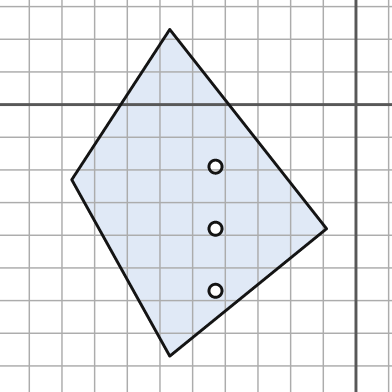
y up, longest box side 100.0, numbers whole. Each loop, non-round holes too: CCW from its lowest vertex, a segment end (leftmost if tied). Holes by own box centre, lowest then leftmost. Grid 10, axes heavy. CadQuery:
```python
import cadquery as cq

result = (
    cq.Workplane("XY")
    .moveTo(-57.0, -77.0)
    .lineTo(-9.0, -38.0)
    .lineTo(-57.0, 23.0)
    .lineTo(-87.0, -23.0)
    .close()
    .moveTo(-43.0, -57.0)
    .circle(2.0)
    .moveTo(-43.0, -38.0)
    .circle(2.0)
    .moveTo(-43.0, -19.0)
    .circle(2.0)
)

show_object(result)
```